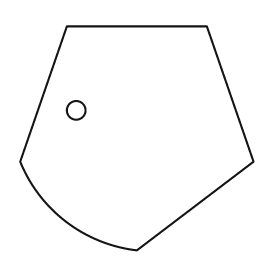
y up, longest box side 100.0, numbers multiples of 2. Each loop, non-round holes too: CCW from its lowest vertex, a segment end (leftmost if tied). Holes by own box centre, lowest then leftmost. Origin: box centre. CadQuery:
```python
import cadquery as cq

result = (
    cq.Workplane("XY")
    .moveTo(0.0, -48.0)
    .lineTo(50.0, -10.0)
    .lineTo(30.0, 48.0)
    .lineTo(-30.0, 48.0)
    .lineTo(-50.0, -10.0)
    .threePointArc((-30.0, -36.0), (0.0, -48.0))
    .close()
    .moveTo(-26.0, 12.0)
    .circle(4.0)
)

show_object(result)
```